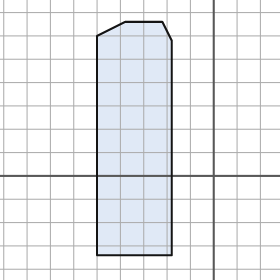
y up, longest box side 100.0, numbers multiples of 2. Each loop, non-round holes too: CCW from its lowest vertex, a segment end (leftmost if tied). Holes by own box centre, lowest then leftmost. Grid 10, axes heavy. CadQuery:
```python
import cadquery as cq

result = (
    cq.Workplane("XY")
    .moveTo(-50.0, -34.0)
    .lineTo(-18.0, -34.0)
    .lineTo(-18.0, 58.0)
    .lineTo(-22.0, 66.0)
    .lineTo(-38.0, 66.0)
    .lineTo(-50.0, 60.0)
    .close()
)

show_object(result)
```